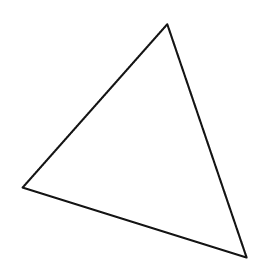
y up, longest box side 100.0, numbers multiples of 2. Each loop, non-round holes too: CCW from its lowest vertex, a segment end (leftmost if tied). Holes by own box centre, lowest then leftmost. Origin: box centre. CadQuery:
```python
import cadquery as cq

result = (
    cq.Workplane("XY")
    .moveTo(48.0, -50.0)
    .lineTo(14.0, 50.0)
    .lineTo(-48.0, -20.0)
    .close()
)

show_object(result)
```